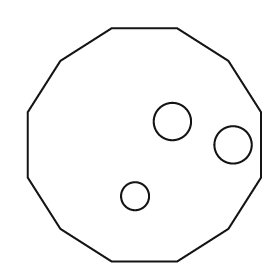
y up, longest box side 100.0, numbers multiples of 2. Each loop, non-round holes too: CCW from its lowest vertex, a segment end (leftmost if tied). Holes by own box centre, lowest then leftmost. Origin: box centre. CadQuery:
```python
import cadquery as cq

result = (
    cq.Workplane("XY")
    .moveTo(-14.0, -50.0)
    .lineTo(14.0, -50.0)
    .lineTo(36.0, -36.0)
    .lineTo(50.0, -14.0)
    .lineTo(50.0, 14.0)
    .lineTo(36.0, 36.0)
    .lineTo(14.0, 50.0)
    .lineTo(-14.0, 50.0)
    .lineTo(-36.0, 36.0)
    .lineTo(-50.0, 14.0)
    .lineTo(-50.0, -14.0)
    .lineTo(-36.0, -36.0)
    .close()
    .moveTo(-4.0, -22.0)
    .circle(6.0)
    .moveTo(38.0, 0.0)
    .circle(8.0)
    .moveTo(12.0, 10.0)
    .circle(8.0)
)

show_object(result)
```